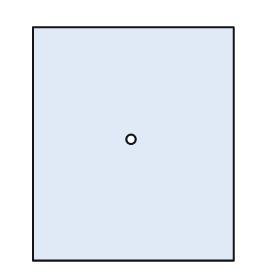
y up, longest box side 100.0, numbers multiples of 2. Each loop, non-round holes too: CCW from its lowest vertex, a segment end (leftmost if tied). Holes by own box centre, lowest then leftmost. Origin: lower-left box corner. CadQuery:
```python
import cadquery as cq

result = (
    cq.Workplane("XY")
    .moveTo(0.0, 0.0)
    .lineTo(86.0, 0.0)
    .lineTo(86.0, 100.0)
    .lineTo(0.0, 100.0)
    .close()
    .moveTo(42.0, 52.0)
    .circle(2.0)
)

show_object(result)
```